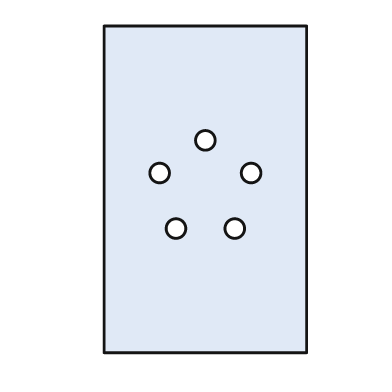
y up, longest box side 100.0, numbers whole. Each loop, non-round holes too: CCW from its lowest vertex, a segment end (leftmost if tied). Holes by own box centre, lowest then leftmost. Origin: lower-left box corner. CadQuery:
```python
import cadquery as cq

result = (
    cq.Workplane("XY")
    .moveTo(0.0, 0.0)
    .lineTo(62.0, 0.0)
    .lineTo(62.0, 100.0)
    .lineTo(0.0, 100.0)
    .close()
    .moveTo(22.0, 38.0)
    .circle(3.0)
    .moveTo(40.0, 38.0)
    .circle(3.0)
    .moveTo(17.0, 55.0)
    .circle(3.0)
    .moveTo(45.0, 55.0)
    .circle(3.0)
    .moveTo(31.0, 65.0)
    .circle(3.0)
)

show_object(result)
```